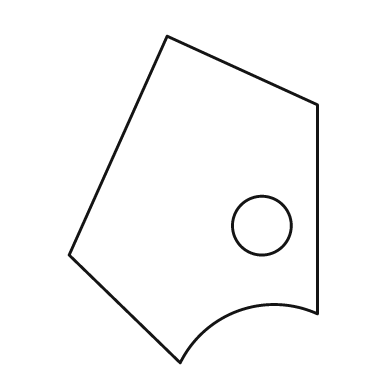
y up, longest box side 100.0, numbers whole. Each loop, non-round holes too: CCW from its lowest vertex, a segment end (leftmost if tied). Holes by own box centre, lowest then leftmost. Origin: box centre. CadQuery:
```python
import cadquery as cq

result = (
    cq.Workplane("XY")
    .moveTo(-4.0, -50.0)
    .threePointArc((14.0, -34.0), (38.0, -35.0))
    .lineTo(38.0, 29.0)
    .lineTo(-8.0, 50.0)
    .lineTo(-38.0, -17.0)
    .close()
    .moveTo(21.0, -8.0)
    .circle(9.0)
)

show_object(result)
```